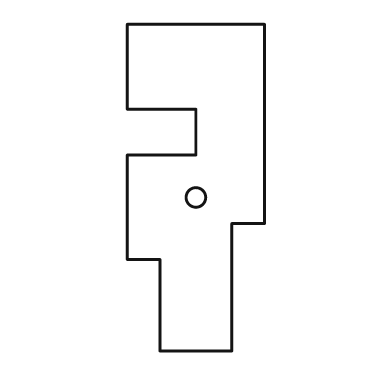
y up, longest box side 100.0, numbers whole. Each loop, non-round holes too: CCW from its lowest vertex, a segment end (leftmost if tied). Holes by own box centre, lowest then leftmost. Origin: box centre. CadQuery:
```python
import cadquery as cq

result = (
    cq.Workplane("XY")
    .moveTo(-11.0, -50.0)
    .lineTo(11.0, -50.0)
    .lineTo(11.0, -11.0)
    .lineTo(21.0, -11.0)
    .lineTo(21.0, 50.0)
    .lineTo(-21.0, 50.0)
    .lineTo(-21.0, 24.0)
    .lineTo(0.0, 24.0)
    .lineTo(0.0, 10.0)
    .lineTo(-21.0, 10.0)
    .lineTo(-21.0, -22.0)
    .lineTo(-11.0, -22.0)
    .close()
    .moveTo(0.0, -3.0)
    .circle(3.0)
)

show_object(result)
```